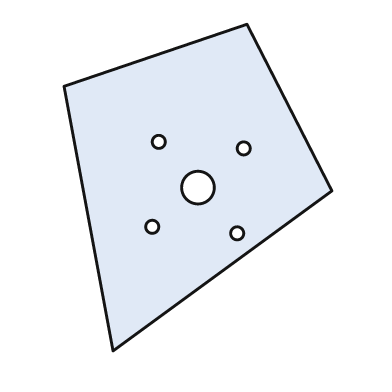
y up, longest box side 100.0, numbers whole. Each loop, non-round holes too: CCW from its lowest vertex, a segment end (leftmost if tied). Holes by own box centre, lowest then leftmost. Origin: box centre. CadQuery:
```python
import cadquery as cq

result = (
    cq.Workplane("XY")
    .moveTo(-26.0, -50.0)
    .lineTo(41.0, -1.0)
    .lineTo(15.0, 50.0)
    .lineTo(-41.0, 31.0)
    .close()
    .moveTo(12.0, -14.0)
    .circle(2.0)
    .moveTo(-14.0, -12.0)
    .circle(2.0)
    .moveTo(0.0, 0.0)
    .circle(5.0)
    .moveTo(14.0, 12.0)
    .circle(2.0)
    .moveTo(-12.0, 14.0)
    .circle(2.0)
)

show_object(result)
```